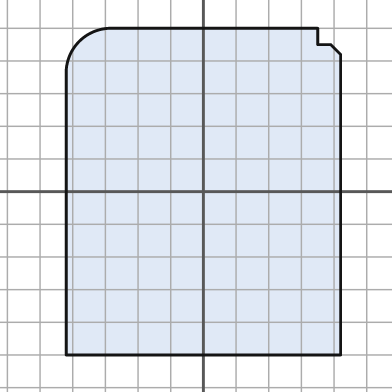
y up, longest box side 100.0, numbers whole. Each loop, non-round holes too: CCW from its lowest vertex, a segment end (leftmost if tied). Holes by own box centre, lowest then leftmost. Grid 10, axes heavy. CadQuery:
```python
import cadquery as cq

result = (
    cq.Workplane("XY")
    .moveTo(-42.0, -50.0)
    .lineTo(42.0, -50.0)
    .lineTo(42.0, 42.0)
    .lineTo(39.0, 45.0)
    .lineTo(35.0, 45.0)
    .lineTo(35.0, 50.0)
    .lineTo(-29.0, 50.0)
    .threePointArc((-38.0, 46.0), (-42.0, 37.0))
    .close()
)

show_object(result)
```